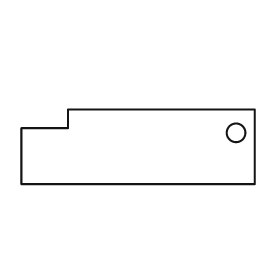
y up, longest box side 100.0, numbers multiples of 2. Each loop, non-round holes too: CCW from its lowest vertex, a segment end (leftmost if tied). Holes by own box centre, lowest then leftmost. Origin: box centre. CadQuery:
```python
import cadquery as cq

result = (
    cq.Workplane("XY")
    .moveTo(-50.0, -16.0)
    .lineTo(50.0, -16.0)
    .lineTo(50.0, 16.0)
    .lineTo(-30.0, 16.0)
    .lineTo(-30.0, 8.0)
    .lineTo(-50.0, 8.0)
    .close()
    .moveTo(42.0, 6.0)
    .circle(4.0)
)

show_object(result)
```